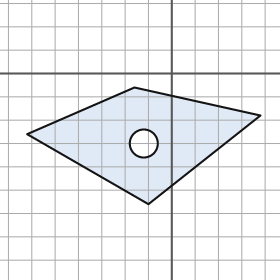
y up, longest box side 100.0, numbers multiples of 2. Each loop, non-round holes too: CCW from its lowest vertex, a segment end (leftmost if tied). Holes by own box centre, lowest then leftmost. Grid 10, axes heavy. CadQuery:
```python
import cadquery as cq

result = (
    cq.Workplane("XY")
    .moveTo(-10.0, -56.0)
    .lineTo(38.0, -18.0)
    .lineTo(-16.0, -6.0)
    .lineTo(-62.0, -26.0)
    .close()
    .moveTo(-12.0, -30.0)
    .circle(6.0)
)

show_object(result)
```